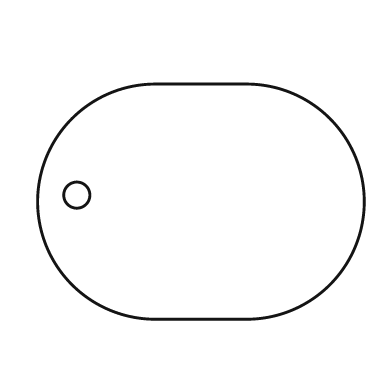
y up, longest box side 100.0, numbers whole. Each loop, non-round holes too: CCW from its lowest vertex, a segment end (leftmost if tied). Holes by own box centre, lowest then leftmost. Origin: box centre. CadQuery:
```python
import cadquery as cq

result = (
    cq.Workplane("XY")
    .moveTo(-14.0, -36.0)
    .lineTo(14.0, -36.0)
    .threePointArc((50.0, 0.0), (14.0, 36.0))
    .lineTo(-14.0, 36.0)
    .threePointArc((-50.0, 0.0), (-14.0, -36.0))
    .close()
    .moveTo(-38.0, 2.0)
    .circle(4.0)
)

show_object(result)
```